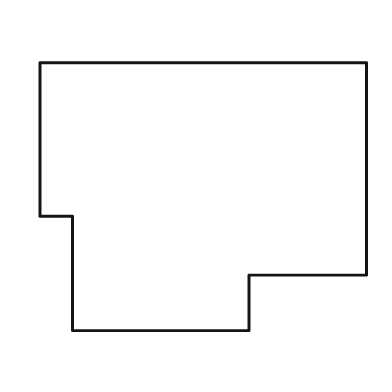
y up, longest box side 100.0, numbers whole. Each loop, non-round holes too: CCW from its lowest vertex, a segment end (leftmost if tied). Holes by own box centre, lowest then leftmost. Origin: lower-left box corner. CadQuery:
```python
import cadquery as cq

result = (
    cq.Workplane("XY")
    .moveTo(10.0, 0.0)
    .lineTo(64.0, 0.0)
    .lineTo(64.0, 17.0)
    .lineTo(100.0, 17.0)
    .lineTo(100.0, 82.0)
    .lineTo(0.0, 82.0)
    .lineTo(0.0, 35.0)
    .lineTo(10.0, 35.0)
    .close()
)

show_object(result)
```